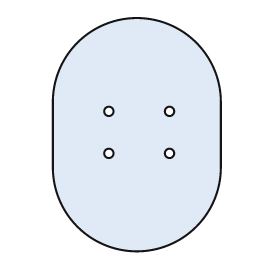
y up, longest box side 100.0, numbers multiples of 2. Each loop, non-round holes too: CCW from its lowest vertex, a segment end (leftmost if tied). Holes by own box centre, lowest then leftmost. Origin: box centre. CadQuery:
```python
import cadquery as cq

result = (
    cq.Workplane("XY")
    .moveTo(-36.0, -14.0)
    .threePointArc((0.0, -50.0), (36.0, -14.0))
    .lineTo(36.0, 14.0)
    .threePointArc((0.0, 50.0), (-36.0, 14.0))
    .close()
    .moveTo(-12.0, -8.0)
    .circle(2.0)
    .moveTo(14.0, -8.0)
    .circle(2.0)
    .moveTo(-12.0, 10.0)
    .circle(2.0)
    .moveTo(14.0, 10.0)
    .circle(2.0)
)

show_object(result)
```